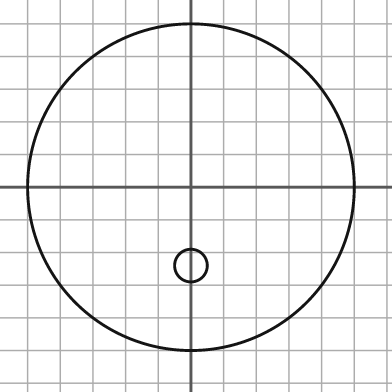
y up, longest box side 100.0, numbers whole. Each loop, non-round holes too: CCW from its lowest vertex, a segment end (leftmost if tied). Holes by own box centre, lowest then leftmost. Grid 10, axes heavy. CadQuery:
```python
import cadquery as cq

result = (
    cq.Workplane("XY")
    .moveTo(0.0, 0.0)
    .circle(50.0)
    .moveTo(0.0, -24.0)
    .circle(5.0)
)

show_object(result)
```